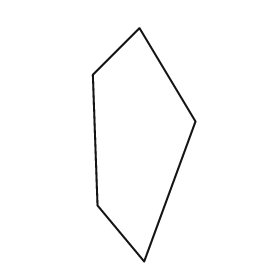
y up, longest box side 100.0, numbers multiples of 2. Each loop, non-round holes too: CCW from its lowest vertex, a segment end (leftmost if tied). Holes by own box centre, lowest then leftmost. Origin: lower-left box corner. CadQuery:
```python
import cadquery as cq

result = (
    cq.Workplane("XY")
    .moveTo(22.0, 0.0)
    .lineTo(44.0, 60.0)
    .lineTo(20.0, 100.0)
    .lineTo(0.0, 80.0)
    .lineTo(2.0, 24.0)
    .close()
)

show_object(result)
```